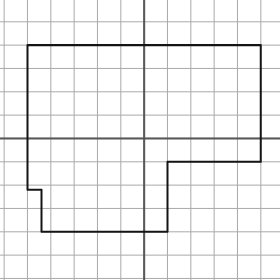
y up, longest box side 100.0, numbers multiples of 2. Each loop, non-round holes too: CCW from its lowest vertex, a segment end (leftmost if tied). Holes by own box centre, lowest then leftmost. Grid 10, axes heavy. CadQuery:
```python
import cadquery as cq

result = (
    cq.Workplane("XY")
    .moveTo(-44.0, -40.0)
    .lineTo(10.0, -40.0)
    .lineTo(10.0, -10.0)
    .lineTo(50.0, -10.0)
    .lineTo(50.0, 40.0)
    .lineTo(-50.0, 40.0)
    .lineTo(-50.0, -22.0)
    .lineTo(-44.0, -22.0)
    .close()
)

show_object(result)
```